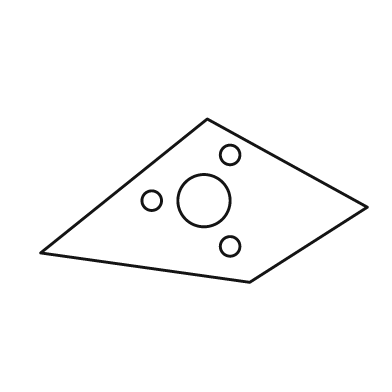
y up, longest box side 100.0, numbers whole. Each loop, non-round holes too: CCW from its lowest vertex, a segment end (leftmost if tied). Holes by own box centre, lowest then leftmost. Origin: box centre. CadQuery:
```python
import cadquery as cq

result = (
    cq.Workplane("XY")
    .moveTo(14.0, -25.0)
    .lineTo(50.0, -2.0)
    .lineTo(1.0, 25.0)
    .lineTo(-50.0, -16.0)
    .close()
    .moveTo(8.0, -14.0)
    .circle(3.0)
    .moveTo(-16.0, 0.0)
    .circle(3.0)
    .moveTo(0.0, 0.0)
    .circle(8.0)
    .moveTo(8.0, 14.0)
    .circle(3.0)
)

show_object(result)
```